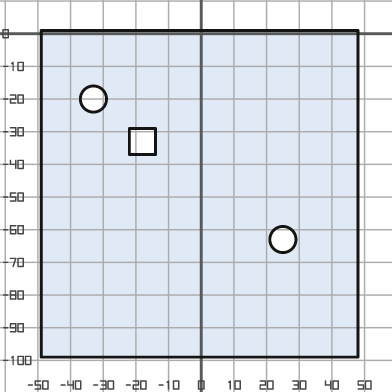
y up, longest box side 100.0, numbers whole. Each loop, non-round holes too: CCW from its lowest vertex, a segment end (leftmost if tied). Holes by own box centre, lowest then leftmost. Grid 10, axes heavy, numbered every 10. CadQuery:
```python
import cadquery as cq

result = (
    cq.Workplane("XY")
    .moveTo(-49.0, -99.0)
    .lineTo(48.0, -99.0)
    .lineTo(48.0, 1.0)
    .lineTo(-49.0, 1.0)
    .close()
    .moveTo(25.0, -63.0)
    .circle(4.0)
    .moveTo(-22.0, -37.0)
    .lineTo(-14.0, -37.0)
    .lineTo(-14.0, -29.0)
    .lineTo(-22.0, -29.0)
    .close()
    .moveTo(-33.0, -20.0)
    .circle(4.0)
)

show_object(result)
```